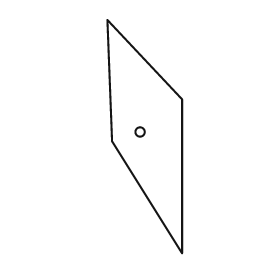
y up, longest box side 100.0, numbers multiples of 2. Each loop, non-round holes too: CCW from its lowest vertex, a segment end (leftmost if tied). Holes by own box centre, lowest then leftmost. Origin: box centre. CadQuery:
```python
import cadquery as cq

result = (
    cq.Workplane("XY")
    .moveTo(16.0, -50.0)
    .lineTo(16.0, 16.0)
    .lineTo(-16.0, 50.0)
    .lineTo(-14.0, -2.0)
    .close()
    .moveTo(-2.0, 2.0)
    .circle(2.0)
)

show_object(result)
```